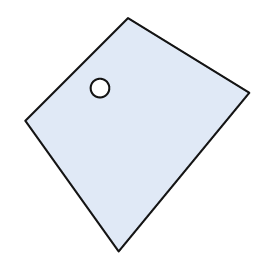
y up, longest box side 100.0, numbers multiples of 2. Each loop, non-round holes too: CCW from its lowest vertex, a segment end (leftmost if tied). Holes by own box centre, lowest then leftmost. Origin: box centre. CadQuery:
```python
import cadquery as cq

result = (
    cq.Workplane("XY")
    .moveTo(-8.0, -50.0)
    .lineTo(48.0, 18.0)
    .lineTo(-4.0, 50.0)
    .lineTo(-48.0, 6.0)
    .close()
    .moveTo(-16.0, 20.0)
    .circle(4.0)
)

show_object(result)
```